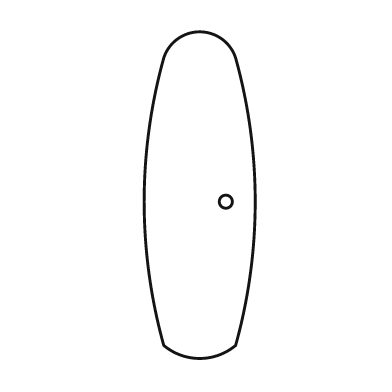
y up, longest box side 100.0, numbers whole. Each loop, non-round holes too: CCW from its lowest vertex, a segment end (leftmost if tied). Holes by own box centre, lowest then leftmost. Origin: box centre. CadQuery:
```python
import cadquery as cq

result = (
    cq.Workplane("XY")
    .moveTo(-11.0, -46.0)
    .threePointArc((0.0, -50.0), (11.0, -46.0))
    .threePointArc((17.0, -2.0), (11.0, 42.0))
    .threePointArc((0.0, 50.0), (-11.0, 42.0))
    .threePointArc((-17.0, -2.0), (-11.0, -46.0))
    .close()
    .moveTo(8.0, -2.0)
    .circle(2.0)
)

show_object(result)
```